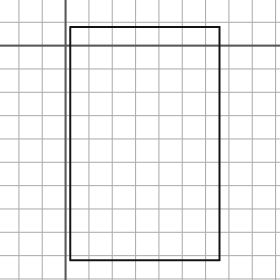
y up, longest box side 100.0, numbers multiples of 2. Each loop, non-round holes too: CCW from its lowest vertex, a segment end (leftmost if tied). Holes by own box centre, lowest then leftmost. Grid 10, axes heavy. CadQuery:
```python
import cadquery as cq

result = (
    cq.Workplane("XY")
    .moveTo(2.0, -92.0)
    .lineTo(66.0, -92.0)
    .lineTo(66.0, 8.0)
    .lineTo(2.0, 8.0)
    .close()
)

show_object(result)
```